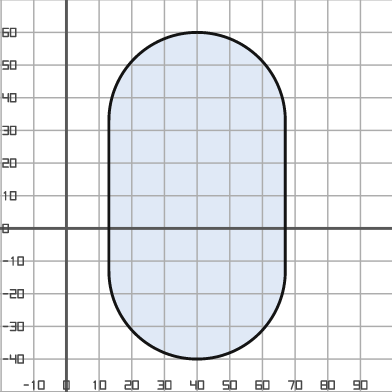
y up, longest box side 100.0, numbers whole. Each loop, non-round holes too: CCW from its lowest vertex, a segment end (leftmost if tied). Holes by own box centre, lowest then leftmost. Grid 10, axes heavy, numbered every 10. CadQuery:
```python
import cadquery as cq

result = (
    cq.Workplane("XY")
    .moveTo(13.0, -13.0)
    .threePointArc((40.0, -40.0), (67.0, -13.0))
    .lineTo(67.0, 33.0)
    .threePointArc((40.0, 60.0), (13.0, 33.0))
    .close()
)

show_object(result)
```